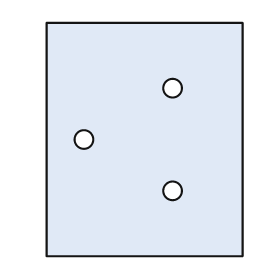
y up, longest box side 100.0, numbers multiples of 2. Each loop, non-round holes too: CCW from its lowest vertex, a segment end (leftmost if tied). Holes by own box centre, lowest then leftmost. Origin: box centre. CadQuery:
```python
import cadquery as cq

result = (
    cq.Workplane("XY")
    .moveTo(-42.0, -50.0)
    .lineTo(42.0, -50.0)
    .lineTo(42.0, 50.0)
    .lineTo(-42.0, 50.0)
    .close()
    .moveTo(12.0, -22.0)
    .circle(4.0)
    .moveTo(-26.0, 0.0)
    .circle(4.0)
    .moveTo(12.0, 22.0)
    .circle(4.0)
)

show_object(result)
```